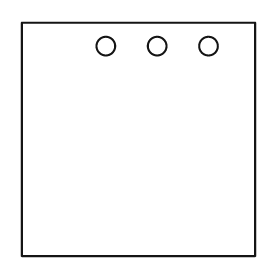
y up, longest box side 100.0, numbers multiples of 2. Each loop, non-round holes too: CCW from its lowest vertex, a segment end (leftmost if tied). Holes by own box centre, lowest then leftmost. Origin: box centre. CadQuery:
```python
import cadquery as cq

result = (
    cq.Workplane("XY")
    .moveTo(-50.0, -50.0)
    .lineTo(50.0, -50.0)
    .lineTo(50.0, 50.0)
    .lineTo(-50.0, 50.0)
    .close()
    .moveTo(-14.0, 40.0)
    .circle(4.0)
    .moveTo(8.0, 40.0)
    .circle(4.0)
    .moveTo(30.0, 40.0)
    .circle(4.0)
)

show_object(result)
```